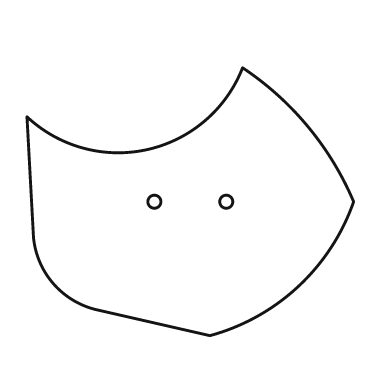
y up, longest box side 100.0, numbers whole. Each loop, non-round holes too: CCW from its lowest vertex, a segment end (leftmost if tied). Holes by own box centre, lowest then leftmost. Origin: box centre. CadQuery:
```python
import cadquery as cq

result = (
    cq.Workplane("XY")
    .moveTo(6.0, -41.0)
    .threePointArc((33.0, -26.0), (50.0, 0.0))
    .threePointArc((36.0, 23.0), (16.0, 41.0))
    .threePointArc((-13.0, 16.0), (-50.0, 26.0))
    .lineTo(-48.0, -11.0)
    .threePointArc((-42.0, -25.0), (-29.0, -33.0))
    .close()
    .moveTo(-11.0, 0.0)
    .circle(2.0)
    .moveTo(11.0, 0.0)
    .circle(2.0)
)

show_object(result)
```